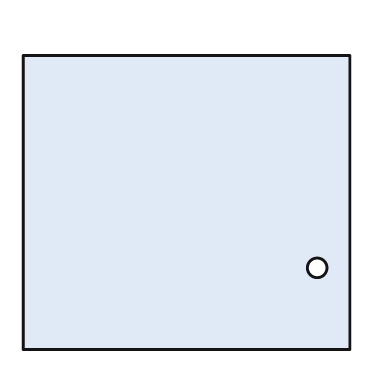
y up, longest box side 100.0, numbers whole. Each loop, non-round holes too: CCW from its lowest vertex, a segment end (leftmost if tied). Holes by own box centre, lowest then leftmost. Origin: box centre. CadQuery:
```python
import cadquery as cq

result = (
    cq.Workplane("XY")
    .moveTo(-50.0, -45.0)
    .lineTo(50.0, -45.0)
    .lineTo(50.0, 45.0)
    .lineTo(-50.0, 45.0)
    .close()
    .moveTo(40.0, -20.0)
    .circle(3.0)
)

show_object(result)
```